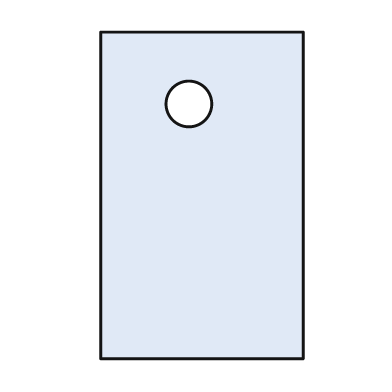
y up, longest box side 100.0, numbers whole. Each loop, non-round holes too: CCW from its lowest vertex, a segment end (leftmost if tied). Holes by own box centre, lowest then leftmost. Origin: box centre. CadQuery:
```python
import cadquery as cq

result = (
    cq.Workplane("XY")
    .moveTo(-31.0, -50.0)
    .lineTo(31.0, -50.0)
    .lineTo(31.0, 50.0)
    .lineTo(-31.0, 50.0)
    .close()
    .moveTo(-4.0, 28.0)
    .circle(7.0)
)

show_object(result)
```